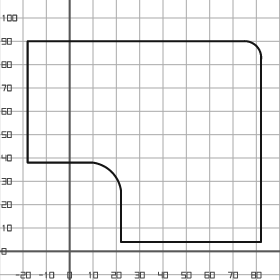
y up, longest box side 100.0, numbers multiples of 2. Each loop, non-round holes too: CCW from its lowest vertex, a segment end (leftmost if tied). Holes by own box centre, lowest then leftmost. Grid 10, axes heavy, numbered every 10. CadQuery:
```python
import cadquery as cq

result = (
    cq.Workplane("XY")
    .moveTo(22.0, 4.0)
    .lineTo(82.0, 4.0)
    .lineTo(82.0, 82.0)
    .threePointArc((80.0, 88.0), (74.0, 90.0))
    .lineTo(-18.0, 90.0)
    .lineTo(-18.0, 38.0)
    .lineTo(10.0, 38.0)
    .threePointArc((18.0, 34.0), (22.0, 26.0))
    .close()
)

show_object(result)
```